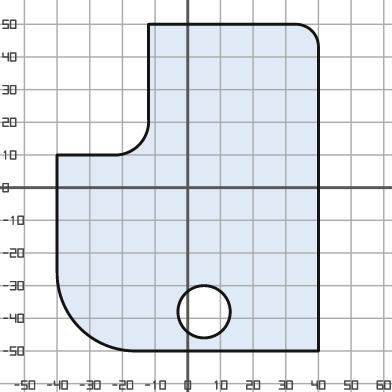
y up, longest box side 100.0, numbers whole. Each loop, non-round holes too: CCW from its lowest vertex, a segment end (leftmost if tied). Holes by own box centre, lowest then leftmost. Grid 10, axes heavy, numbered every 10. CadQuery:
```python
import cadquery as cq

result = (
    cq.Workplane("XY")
    .moveTo(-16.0, -50.0)
    .lineTo(40.0, -50.0)
    .lineTo(40.0, 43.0)
    .threePointArc((38.0, 48.0), (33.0, 50.0))
    .lineTo(-12.0, 50.0)
    .lineTo(-12.0, 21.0)
    .threePointArc((-15.0, 13.0), (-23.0, 10.0))
    .lineTo(-40.0, 10.0)
    .lineTo(-40.0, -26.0)
    .threePointArc((-33.0, -43.0), (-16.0, -50.0))
    .close()
    .moveTo(5.0, -38.0)
    .circle(8.0)
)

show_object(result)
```